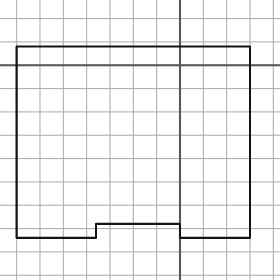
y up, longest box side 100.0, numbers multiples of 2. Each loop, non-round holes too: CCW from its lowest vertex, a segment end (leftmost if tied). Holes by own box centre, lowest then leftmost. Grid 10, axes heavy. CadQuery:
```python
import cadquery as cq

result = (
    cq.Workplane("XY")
    .moveTo(-70.0, -74.0)
    .lineTo(-36.0, -74.0)
    .lineTo(-36.0, -68.0)
    .lineTo(0.0, -68.0)
    .lineTo(0.0, -74.0)
    .lineTo(30.0, -74.0)
    .lineTo(30.0, 8.0)
    .lineTo(-70.0, 8.0)
    .close()
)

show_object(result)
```